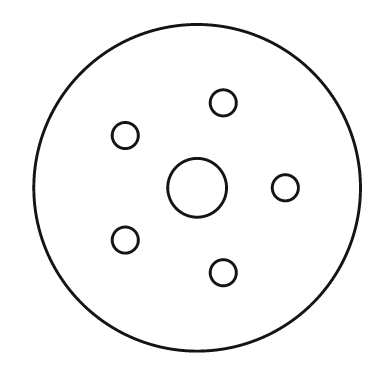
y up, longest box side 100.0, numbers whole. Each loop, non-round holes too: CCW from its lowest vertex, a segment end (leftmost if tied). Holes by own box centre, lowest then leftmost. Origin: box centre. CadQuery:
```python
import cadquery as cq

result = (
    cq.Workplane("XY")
    .moveTo(0.0, 0.0)
    .circle(50.0)
    .moveTo(8.0, -26.0)
    .circle(4.0)
    .moveTo(-22.0, -16.0)
    .circle(4.0)
    .moveTo(0.0, 0.0)
    .circle(9.0)
    .moveTo(27.0, 0.0)
    .circle(4.0)
    .moveTo(-22.0, 16.0)
    .circle(4.0)
    .moveTo(8.0, 26.0)
    .circle(4.0)
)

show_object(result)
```